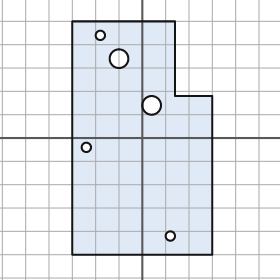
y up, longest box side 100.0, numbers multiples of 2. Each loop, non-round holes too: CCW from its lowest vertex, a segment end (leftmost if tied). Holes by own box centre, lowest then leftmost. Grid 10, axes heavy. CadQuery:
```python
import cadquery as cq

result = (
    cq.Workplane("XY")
    .moveTo(-30.0, -50.0)
    .lineTo(30.0, -50.0)
    .lineTo(30.0, 18.0)
    .lineTo(14.0, 18.0)
    .lineTo(14.0, 50.0)
    .lineTo(-30.0, 50.0)
    .close()
    .moveTo(12.0, -42.0)
    .circle(2.0)
    .moveTo(-24.0, -4.0)
    .circle(2.0)
    .moveTo(4.0, 14.0)
    .circle(4.0)
    .moveTo(-10.0, 34.0)
    .circle(4.0)
    .moveTo(-18.0, 44.0)
    .circle(2.0)
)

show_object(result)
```